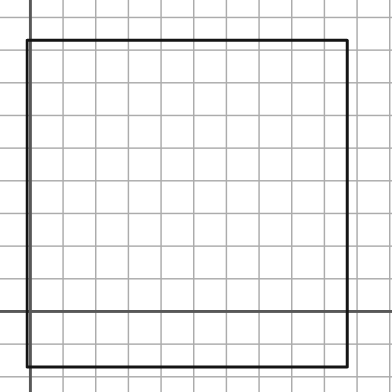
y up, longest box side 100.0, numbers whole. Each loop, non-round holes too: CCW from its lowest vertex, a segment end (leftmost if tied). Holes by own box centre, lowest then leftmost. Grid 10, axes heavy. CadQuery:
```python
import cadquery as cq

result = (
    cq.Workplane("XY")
    .moveTo(-1.0, -17.0)
    .lineTo(97.0, -17.0)
    .lineTo(97.0, 83.0)
    .lineTo(-1.0, 83.0)
    .close()
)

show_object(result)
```